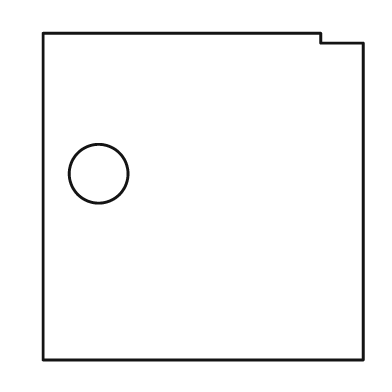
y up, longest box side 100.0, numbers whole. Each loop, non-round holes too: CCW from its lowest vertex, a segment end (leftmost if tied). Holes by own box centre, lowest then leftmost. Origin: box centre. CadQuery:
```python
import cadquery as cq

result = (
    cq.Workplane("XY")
    .moveTo(-49.0, -50.0)
    .lineTo(49.0, -50.0)
    .lineTo(49.0, 47.0)
    .lineTo(36.0, 47.0)
    .lineTo(36.0, 50.0)
    .lineTo(-49.0, 50.0)
    .close()
    .moveTo(-32.0, 7.0)
    .circle(9.0)
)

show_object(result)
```